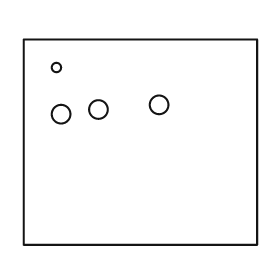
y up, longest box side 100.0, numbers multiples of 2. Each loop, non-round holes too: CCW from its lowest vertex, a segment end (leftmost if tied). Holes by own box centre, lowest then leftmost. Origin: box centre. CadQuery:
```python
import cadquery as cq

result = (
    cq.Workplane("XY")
    .moveTo(-50.0, -44.0)
    .lineTo(50.0, -44.0)
    .lineTo(50.0, 44.0)
    .lineTo(-50.0, 44.0)
    .close()
    .moveTo(-34.0, 12.0)
    .circle(4.0)
    .moveTo(-18.0, 14.0)
    .circle(4.0)
    .moveTo(8.0, 16.0)
    .circle(4.0)
    .moveTo(-36.0, 32.0)
    .circle(2.0)
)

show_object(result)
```